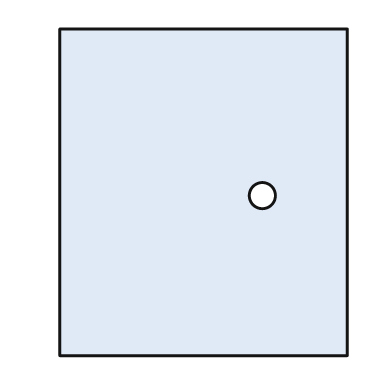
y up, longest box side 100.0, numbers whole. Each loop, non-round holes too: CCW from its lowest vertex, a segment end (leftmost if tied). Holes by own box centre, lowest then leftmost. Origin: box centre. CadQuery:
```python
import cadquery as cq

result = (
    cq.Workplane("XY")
    .moveTo(-44.0, -50.0)
    .lineTo(44.0, -50.0)
    .lineTo(44.0, 50.0)
    .lineTo(-44.0, 50.0)
    .close()
    .moveTo(18.0, -1.0)
    .circle(4.0)
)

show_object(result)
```